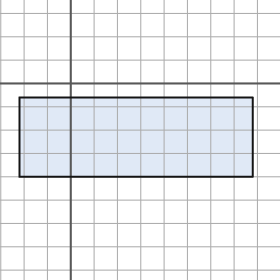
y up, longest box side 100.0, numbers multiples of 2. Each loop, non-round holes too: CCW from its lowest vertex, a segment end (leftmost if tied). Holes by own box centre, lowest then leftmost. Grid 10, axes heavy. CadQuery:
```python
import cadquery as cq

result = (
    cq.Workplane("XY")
    .moveTo(-22.0, -40.0)
    .lineTo(78.0, -40.0)
    .lineTo(78.0, -6.0)
    .lineTo(-22.0, -6.0)
    .close()
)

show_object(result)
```